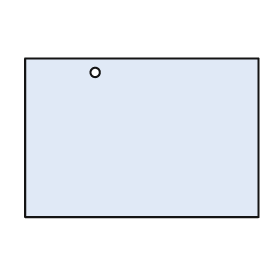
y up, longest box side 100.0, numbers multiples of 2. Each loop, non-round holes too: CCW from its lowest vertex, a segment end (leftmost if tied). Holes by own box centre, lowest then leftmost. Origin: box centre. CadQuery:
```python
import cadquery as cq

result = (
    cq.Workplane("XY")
    .moveTo(-50.0, -34.0)
    .lineTo(50.0, -34.0)
    .lineTo(50.0, 34.0)
    .lineTo(-50.0, 34.0)
    .close()
    .moveTo(-20.0, 28.0)
    .circle(2.0)
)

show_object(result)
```